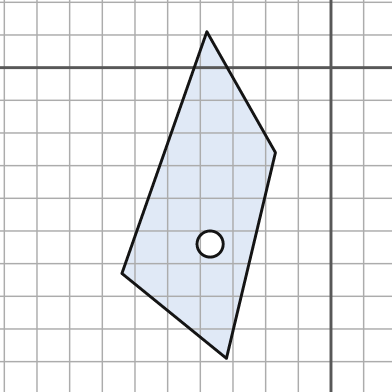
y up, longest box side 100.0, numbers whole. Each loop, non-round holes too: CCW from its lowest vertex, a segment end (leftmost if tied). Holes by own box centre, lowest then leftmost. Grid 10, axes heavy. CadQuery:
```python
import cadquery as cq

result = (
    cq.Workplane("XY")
    .moveTo(-32.0, -89.0)
    .lineTo(-17.0, -26.0)
    .lineTo(-38.0, 11.0)
    .lineTo(-64.0, -63.0)
    .close()
    .moveTo(-37.0, -54.0)
    .circle(4.0)
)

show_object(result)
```